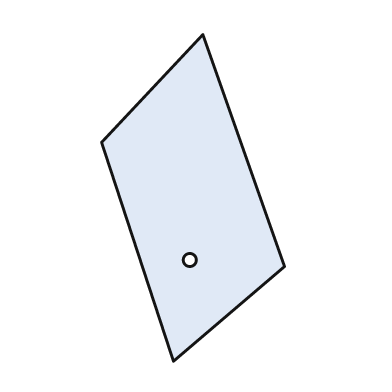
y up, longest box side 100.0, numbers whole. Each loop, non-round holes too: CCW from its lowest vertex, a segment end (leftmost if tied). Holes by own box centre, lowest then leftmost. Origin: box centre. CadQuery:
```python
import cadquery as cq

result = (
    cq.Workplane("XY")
    .moveTo(-6.0, -50.0)
    .lineTo(28.0, -21.0)
    .lineTo(3.0, 50.0)
    .lineTo(-28.0, 17.0)
    .close()
    .moveTo(-1.0, -19.0)
    .circle(2.0)
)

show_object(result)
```